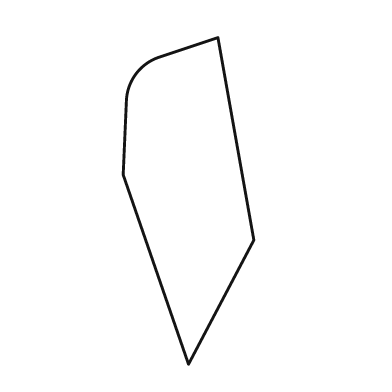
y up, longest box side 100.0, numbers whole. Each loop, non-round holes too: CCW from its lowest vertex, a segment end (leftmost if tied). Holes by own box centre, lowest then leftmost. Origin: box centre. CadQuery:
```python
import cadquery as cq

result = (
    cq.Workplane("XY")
    .moveTo(0.0, -50.0)
    .lineTo(20.0, -12.0)
    .lineTo(9.0, 50.0)
    .lineTo(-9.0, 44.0)
    .threePointArc((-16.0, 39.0), (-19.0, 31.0))
    .lineTo(-20.0, 8.0)
    .close()
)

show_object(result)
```